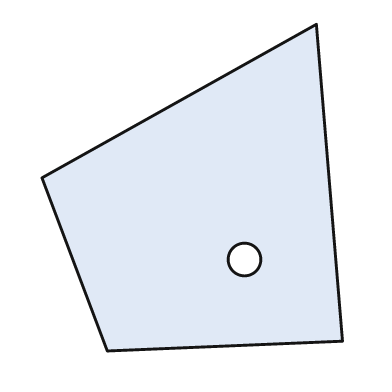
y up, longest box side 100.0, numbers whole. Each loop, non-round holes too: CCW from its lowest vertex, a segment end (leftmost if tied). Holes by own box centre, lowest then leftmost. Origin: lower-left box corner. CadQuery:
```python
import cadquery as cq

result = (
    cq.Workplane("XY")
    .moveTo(20.0, 0.0)
    .lineTo(92.0, 3.0)
    .lineTo(84.0, 100.0)
    .lineTo(0.0, 53.0)
    .close()
    .moveTo(62.0, 28.0)
    .circle(5.0)
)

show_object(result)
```